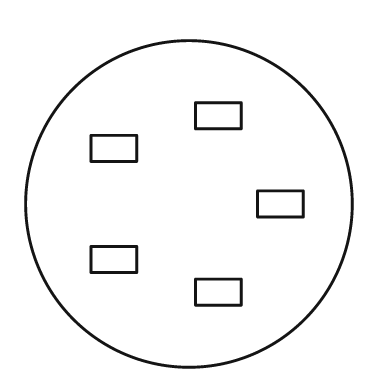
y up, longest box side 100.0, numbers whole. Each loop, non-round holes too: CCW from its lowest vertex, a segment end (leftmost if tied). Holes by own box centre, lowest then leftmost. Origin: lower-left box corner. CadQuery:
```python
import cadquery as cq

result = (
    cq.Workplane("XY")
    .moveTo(50.0, 50.0)
    .circle(50.0)
    .moveTo(52.0, 19.0)
    .lineTo(66.0, 19.0)
    .lineTo(66.0, 27.0)
    .lineTo(52.0, 27.0)
    .close()
    .moveTo(20.0, 29.0)
    .lineTo(34.0, 29.0)
    .lineTo(34.0, 37.0)
    .lineTo(20.0, 37.0)
    .close()
    .moveTo(71.0, 46.0)
    .lineTo(85.0, 46.0)
    .lineTo(85.0, 54.0)
    .lineTo(71.0, 54.0)
    .close()
    .moveTo(20.0, 63.0)
    .lineTo(34.0, 63.0)
    .lineTo(34.0, 71.0)
    .lineTo(20.0, 71.0)
    .close()
    .moveTo(52.0, 73.0)
    .lineTo(66.0, 73.0)
    .lineTo(66.0, 81.0)
    .lineTo(52.0, 81.0)
    .close()
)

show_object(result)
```